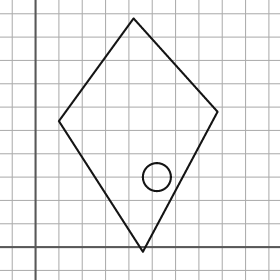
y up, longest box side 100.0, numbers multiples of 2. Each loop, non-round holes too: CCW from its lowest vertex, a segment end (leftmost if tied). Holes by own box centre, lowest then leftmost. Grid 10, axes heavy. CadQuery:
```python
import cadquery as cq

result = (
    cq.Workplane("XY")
    .moveTo(46.0, -2.0)
    .lineTo(78.0, 58.0)
    .lineTo(42.0, 98.0)
    .lineTo(10.0, 54.0)
    .close()
    .moveTo(52.0, 30.0)
    .circle(6.0)
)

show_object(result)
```